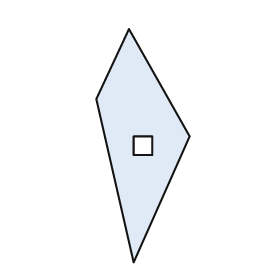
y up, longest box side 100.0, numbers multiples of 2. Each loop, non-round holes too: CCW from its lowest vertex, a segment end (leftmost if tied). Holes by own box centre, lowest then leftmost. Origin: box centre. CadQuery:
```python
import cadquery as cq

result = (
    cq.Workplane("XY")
    .moveTo(-4.0, -50.0)
    .lineTo(20.0, 4.0)
    .lineTo(-6.0, 50.0)
    .lineTo(-20.0, 20.0)
    .close()
    .moveTo(-4.0, -4.0)
    .lineTo(4.0, -4.0)
    .lineTo(4.0, 4.0)
    .lineTo(-4.0, 4.0)
    .close()
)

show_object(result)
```